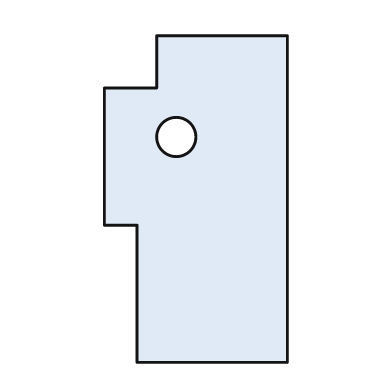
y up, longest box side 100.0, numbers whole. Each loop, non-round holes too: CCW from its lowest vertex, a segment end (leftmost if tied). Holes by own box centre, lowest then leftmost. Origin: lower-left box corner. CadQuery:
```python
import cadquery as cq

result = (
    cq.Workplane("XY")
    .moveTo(10.0, 0.0)
    .lineTo(56.0, 0.0)
    .lineTo(56.0, 100.0)
    .lineTo(16.0, 100.0)
    .lineTo(16.0, 84.0)
    .lineTo(0.0, 84.0)
    .lineTo(0.0, 42.0)
    .lineTo(10.0, 42.0)
    .close()
    .moveTo(22.0, 69.0)
    .circle(6.0)
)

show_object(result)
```